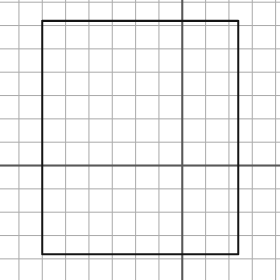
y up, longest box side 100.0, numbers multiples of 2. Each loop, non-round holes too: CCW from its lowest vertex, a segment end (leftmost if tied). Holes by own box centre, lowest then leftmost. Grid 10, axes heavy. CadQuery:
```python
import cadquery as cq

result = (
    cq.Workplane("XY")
    .moveTo(-60.0, -38.0)
    .lineTo(24.0, -38.0)
    .lineTo(24.0, 62.0)
    .lineTo(-60.0, 62.0)
    .close()
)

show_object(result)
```